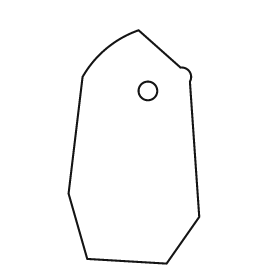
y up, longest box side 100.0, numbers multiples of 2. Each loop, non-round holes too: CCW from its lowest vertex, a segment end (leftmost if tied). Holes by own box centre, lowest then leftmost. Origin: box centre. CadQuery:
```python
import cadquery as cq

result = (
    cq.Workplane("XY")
    .moveTo(14.0, -50.0)
    .lineTo(28.0, -30.0)
    .lineTo(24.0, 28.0)
    .threePointArc((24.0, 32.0), (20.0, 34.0))
    .lineTo(2.0, 50.0)
    .threePointArc((-12.0, 42.0), (-22.0, 30.0))
    .lineTo(-28.0, -20.0)
    .lineTo(-20.0, -48.0)
    .close()
    .moveTo(6.0, 24.0)
    .circle(4.0)
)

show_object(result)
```